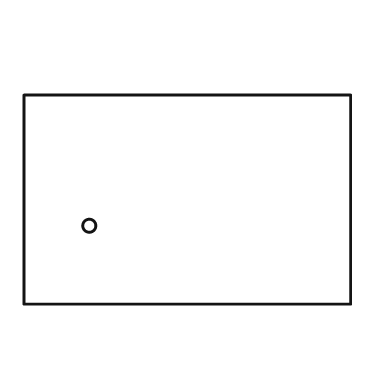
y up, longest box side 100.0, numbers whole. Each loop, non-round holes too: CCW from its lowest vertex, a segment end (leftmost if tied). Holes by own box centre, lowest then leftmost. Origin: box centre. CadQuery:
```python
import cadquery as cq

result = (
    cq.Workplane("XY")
    .moveTo(-50.0, -32.0)
    .lineTo(50.0, -32.0)
    .lineTo(50.0, 32.0)
    .lineTo(-50.0, 32.0)
    .close()
    .moveTo(-30.0, -8.0)
    .circle(2.0)
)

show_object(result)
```